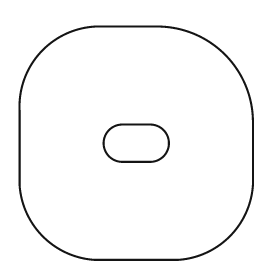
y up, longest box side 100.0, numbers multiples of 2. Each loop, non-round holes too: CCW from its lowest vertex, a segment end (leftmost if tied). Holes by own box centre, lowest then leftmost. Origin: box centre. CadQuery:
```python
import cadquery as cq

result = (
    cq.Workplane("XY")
    .moveTo(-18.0, -50.0)
    .lineTo(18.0, -50.0)
    .threePointArc((40.0, -40.0), (50.0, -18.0))
    .lineTo(50.0, 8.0)
    .threePointArc((38.0, 38.0), (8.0, 50.0))
    .lineTo(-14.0, 50.0)
    .threePointArc((-40.0, 40.0), (-50.0, 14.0))
    .lineTo(-50.0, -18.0)
    .threePointArc((-40.0, -40.0), (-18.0, -50.0))
    .close()
    .moveTo(-6.0, -8.0)
    .lineTo(6.0, -8.0)
    .threePointArc((14.0, 0.0), (6.0, 8.0))
    .lineTo(-6.0, 8.0)
    .threePointArc((-14.0, 0.0), (-6.0, -8.0))
    .close()
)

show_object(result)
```